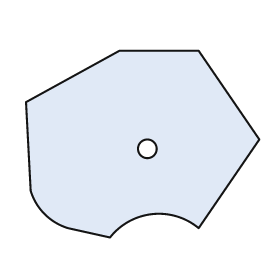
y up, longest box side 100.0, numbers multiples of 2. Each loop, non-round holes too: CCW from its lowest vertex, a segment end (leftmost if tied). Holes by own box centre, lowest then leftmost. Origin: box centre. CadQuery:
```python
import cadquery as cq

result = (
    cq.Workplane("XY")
    .moveTo(-14.0, -40.0)
    .threePointArc((4.0, -30.0), (24.0, -36.0))
    .lineTo(50.0, 2.0)
    .lineTo(24.0, 40.0)
    .lineTo(-10.0, 40.0)
    .lineTo(-50.0, 18.0)
    .lineTo(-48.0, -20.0)
    .threePointArc((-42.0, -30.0), (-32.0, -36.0))
    .close()
    .moveTo(2.0, -2.0)
    .circle(4.0)
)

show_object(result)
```